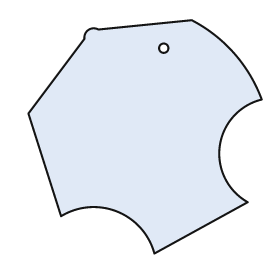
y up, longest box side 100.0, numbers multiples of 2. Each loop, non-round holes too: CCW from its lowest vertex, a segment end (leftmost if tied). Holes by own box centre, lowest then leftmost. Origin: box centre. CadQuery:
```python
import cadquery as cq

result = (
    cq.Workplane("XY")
    .moveTo(4.0, -50.0)
    .lineTo(44.0, -28.0)
    .threePointArc((32.0, -4.0), (50.0, 16.0))
    .threePointArc((38.0, 36.0), (20.0, 50.0))
    .lineTo(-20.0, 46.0)
    .threePointArc((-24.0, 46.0), (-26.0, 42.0))
    .lineTo(-50.0, 10.0)
    .lineTo(-36.0, -34.0)
    .threePointArc((-12.0, -32.0), (4.0, -50.0))
    .close()
    .moveTo(8.0, 38.0)
    .circle(2.0)
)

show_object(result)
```